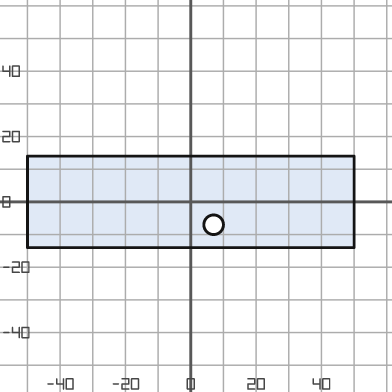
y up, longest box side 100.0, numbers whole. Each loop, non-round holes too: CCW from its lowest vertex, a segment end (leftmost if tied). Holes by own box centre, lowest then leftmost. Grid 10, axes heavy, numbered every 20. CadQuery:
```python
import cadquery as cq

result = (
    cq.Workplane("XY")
    .moveTo(-50.0, -14.0)
    .lineTo(50.0, -14.0)
    .lineTo(50.0, 14.0)
    .lineTo(-50.0, 14.0)
    .close()
    .moveTo(7.0, -7.0)
    .circle(3.0)
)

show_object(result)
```